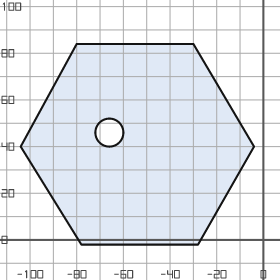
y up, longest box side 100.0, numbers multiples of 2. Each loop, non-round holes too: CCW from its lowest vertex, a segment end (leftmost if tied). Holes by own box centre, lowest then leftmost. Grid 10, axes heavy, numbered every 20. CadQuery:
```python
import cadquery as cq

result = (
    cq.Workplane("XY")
    .moveTo(-78.0, -2.0)
    .lineTo(-28.0, -2.0)
    .lineTo(-4.0, 40.0)
    .lineTo(-30.0, 84.0)
    .lineTo(-80.0, 84.0)
    .lineTo(-104.0, 40.0)
    .close()
    .moveTo(-66.0, 46.0)
    .circle(6.0)
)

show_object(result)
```